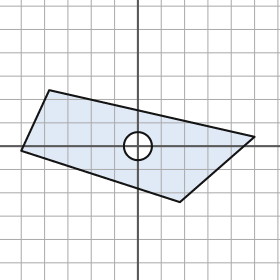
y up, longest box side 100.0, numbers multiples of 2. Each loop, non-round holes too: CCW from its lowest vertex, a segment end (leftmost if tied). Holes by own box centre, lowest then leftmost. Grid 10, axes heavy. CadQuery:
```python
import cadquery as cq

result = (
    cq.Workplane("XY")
    .moveTo(18.0, -24.0)
    .lineTo(50.0, 4.0)
    .lineTo(-38.0, 24.0)
    .lineTo(-50.0, -2.0)
    .close()
    .moveTo(0.0, 0.0)
    .circle(6.0)
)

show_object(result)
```